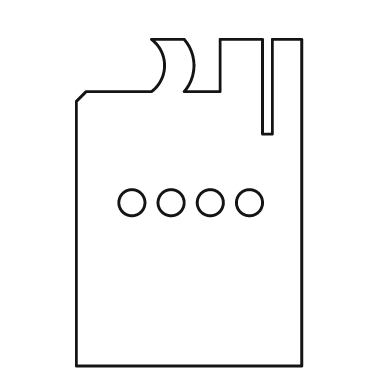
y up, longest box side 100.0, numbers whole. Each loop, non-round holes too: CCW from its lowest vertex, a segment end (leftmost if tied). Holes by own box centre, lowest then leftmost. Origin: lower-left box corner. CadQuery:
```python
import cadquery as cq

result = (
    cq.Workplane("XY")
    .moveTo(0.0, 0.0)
    .lineTo(69.0, 0.0)
    .lineTo(69.0, 100.0)
    .lineTo(60.0, 100.0)
    .lineTo(60.0, 71.0)
    .lineTo(57.0, 71.0)
    .lineTo(57.0, 100.0)
    .lineTo(44.0, 100.0)
    .lineTo(44.0, 84.0)
    .lineTo(33.0, 84.0)
    .threePointArc((36.0, 92.0), (33.0, 100.0))
    .lineTo(23.0, 100.0)
    .threePointArc((27.0, 92.0), (23.0, 84.0))
    .lineTo(3.0, 84.0)
    .lineTo(0.0, 81.0)
    .close()
    .moveTo(17.0, 50.0)
    .circle(4.0)
    .moveTo(29.0, 50.0)
    .circle(4.0)
    .moveTo(41.0, 50.0)
    .circle(4.0)
    .moveTo(53.0, 50.0)
    .circle(4.0)
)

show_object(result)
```